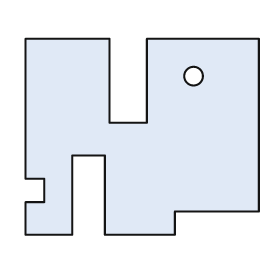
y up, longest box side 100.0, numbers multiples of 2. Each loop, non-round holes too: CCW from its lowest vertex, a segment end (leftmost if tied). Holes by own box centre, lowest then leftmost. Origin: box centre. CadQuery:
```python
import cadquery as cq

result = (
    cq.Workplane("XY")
    .moveTo(-50.0, -42.0)
    .lineTo(-30.0, -42.0)
    .lineTo(-30.0, -8.0)
    .lineTo(-16.0, -8.0)
    .lineTo(-16.0, -42.0)
    .lineTo(14.0, -42.0)
    .lineTo(14.0, -32.0)
    .lineTo(50.0, -32.0)
    .lineTo(50.0, 42.0)
    .lineTo(2.0, 42.0)
    .lineTo(2.0, 6.0)
    .lineTo(-14.0, 6.0)
    .lineTo(-14.0, 42.0)
    .lineTo(-50.0, 42.0)
    .lineTo(-50.0, -18.0)
    .lineTo(-42.0, -18.0)
    .lineTo(-42.0, -28.0)
    .lineTo(-50.0, -28.0)
    .close()
    .moveTo(22.0, 26.0)
    .circle(4.0)
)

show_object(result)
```